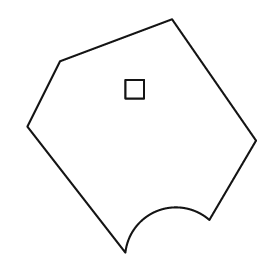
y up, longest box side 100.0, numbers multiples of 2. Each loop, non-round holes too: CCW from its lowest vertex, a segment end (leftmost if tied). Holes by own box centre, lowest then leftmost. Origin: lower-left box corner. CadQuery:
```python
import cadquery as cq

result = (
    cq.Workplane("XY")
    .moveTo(42.0, 0.0)
    .threePointArc((56.0, 18.0), (78.0, 14.0))
    .lineTo(98.0, 48.0)
    .lineTo(62.0, 100.0)
    .lineTo(14.0, 82.0)
    .lineTo(0.0, 54.0)
    .close()
    .moveTo(42.0, 66.0)
    .lineTo(50.0, 66.0)
    .lineTo(50.0, 74.0)
    .lineTo(42.0, 74.0)
    .close()
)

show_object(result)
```